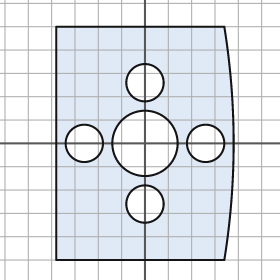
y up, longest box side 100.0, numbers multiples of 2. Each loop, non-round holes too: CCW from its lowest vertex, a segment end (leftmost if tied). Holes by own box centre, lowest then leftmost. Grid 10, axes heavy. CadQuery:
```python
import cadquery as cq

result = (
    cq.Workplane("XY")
    .moveTo(-38.0, -50.0)
    .lineTo(34.0, -50.0)
    .threePointArc((38.0, 0.0), (34.0, 50.0))
    .lineTo(-38.0, 50.0)
    .close()
    .moveTo(0.0, -26.0)
    .circle(8.0)
    .moveTo(-26.0, 0.0)
    .circle(8.0)
    .moveTo(0.0, 0.0)
    .circle(14.0)
    .moveTo(26.0, 0.0)
    .circle(8.0)
    .moveTo(0.0, 26.0)
    .circle(8.0)
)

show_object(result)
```